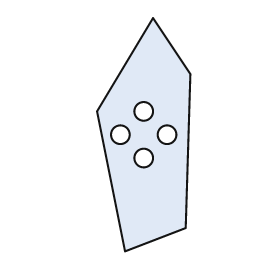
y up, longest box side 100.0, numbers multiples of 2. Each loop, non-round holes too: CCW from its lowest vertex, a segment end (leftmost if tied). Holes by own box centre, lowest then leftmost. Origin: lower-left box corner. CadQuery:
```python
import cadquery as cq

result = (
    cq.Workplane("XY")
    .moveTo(12.0, 0.0)
    .lineTo(38.0, 10.0)
    .lineTo(40.0, 76.0)
    .lineTo(24.0, 100.0)
    .lineTo(0.0, 60.0)
    .close()
    .moveTo(20.0, 40.0)
    .circle(4.0)
    .moveTo(10.0, 50.0)
    .circle(4.0)
    .moveTo(30.0, 50.0)
    .circle(4.0)
    .moveTo(20.0, 60.0)
    .circle(4.0)
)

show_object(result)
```